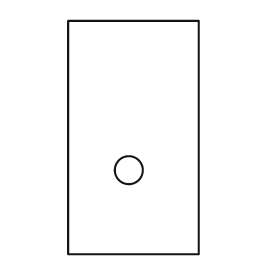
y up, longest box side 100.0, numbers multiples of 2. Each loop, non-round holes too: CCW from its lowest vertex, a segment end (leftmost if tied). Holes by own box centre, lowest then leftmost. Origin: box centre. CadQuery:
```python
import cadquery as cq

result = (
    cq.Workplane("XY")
    .moveTo(-28.0, -50.0)
    .lineTo(28.0, -50.0)
    .lineTo(28.0, 50.0)
    .lineTo(-28.0, 50.0)
    .close()
    .moveTo(-2.0, -14.0)
    .circle(6.0)
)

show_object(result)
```